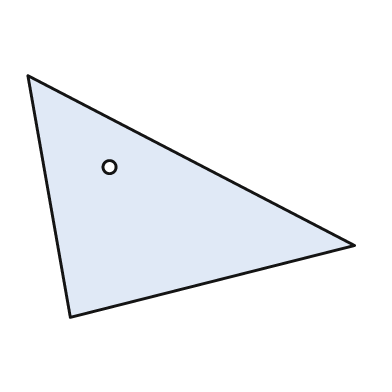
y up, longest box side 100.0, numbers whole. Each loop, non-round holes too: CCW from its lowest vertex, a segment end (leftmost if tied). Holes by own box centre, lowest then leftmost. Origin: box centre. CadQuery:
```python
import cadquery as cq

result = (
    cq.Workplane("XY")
    .moveTo(-37.0, -37.0)
    .lineTo(50.0, -15.0)
    .lineTo(-50.0, 37.0)
    .close()
    .moveTo(-25.0, 9.0)
    .circle(2.0)
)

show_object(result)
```